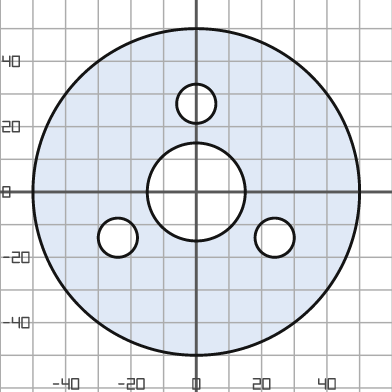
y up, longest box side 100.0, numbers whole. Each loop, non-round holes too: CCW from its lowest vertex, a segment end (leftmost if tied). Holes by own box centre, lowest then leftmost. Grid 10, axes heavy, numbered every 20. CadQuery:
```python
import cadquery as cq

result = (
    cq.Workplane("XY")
    .moveTo(0.0, 0.0)
    .circle(50.0)
    .moveTo(-24.0, -14.0)
    .circle(6.0)
    .moveTo(24.0, -14.0)
    .circle(6.0)
    .moveTo(0.0, 0.0)
    .circle(15.0)
    .moveTo(0.0, 27.0)
    .circle(6.0)
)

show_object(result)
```